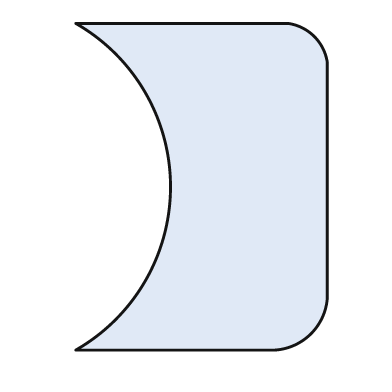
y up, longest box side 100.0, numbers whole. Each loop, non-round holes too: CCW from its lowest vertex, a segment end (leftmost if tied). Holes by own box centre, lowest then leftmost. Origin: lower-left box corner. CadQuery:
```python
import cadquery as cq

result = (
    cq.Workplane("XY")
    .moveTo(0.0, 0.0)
    .lineTo(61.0, 0.0)
    .threePointArc((72.0, 5.0), (77.0, 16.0))
    .lineTo(77.0, 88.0)
    .threePointArc((73.0, 96.0), (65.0, 100.0))
    .lineTo(0.0, 100.0)
    .threePointArc((29.0, 50.0), (0.0, 0.0))
    .close()
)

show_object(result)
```